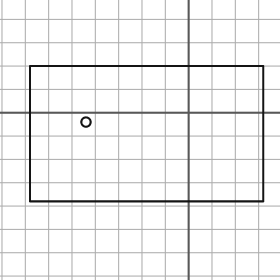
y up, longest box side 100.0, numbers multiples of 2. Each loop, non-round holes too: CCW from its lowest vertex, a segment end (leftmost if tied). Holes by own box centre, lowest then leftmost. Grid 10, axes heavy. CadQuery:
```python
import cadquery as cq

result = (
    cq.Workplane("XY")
    .moveTo(-68.0, -38.0)
    .lineTo(32.0, -38.0)
    .lineTo(32.0, 20.0)
    .lineTo(-68.0, 20.0)
    .close()
    .moveTo(-44.0, -4.0)
    .circle(2.0)
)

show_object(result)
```